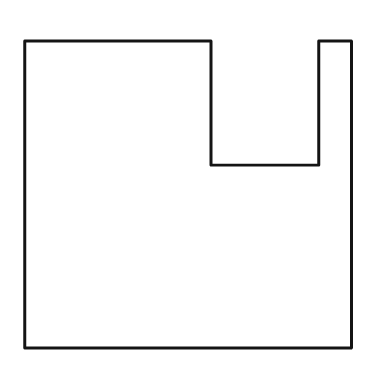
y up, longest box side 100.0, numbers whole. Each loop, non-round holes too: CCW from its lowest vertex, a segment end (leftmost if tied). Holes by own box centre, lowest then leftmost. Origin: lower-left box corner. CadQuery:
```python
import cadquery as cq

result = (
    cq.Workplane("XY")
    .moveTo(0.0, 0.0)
    .lineTo(100.0, 0.0)
    .lineTo(100.0, 94.0)
    .lineTo(90.0, 94.0)
    .lineTo(90.0, 56.0)
    .lineTo(57.0, 56.0)
    .lineTo(57.0, 94.0)
    .lineTo(0.0, 94.0)
    .close()
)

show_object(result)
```